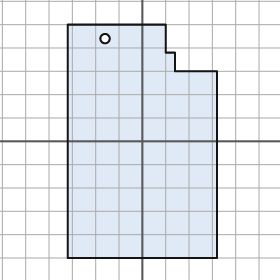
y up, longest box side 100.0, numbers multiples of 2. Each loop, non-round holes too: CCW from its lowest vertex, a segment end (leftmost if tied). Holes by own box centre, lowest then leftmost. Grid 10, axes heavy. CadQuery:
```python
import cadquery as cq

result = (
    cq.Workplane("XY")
    .moveTo(-32.0, -50.0)
    .lineTo(32.0, -50.0)
    .lineTo(32.0, 30.0)
    .lineTo(14.0, 30.0)
    .lineTo(14.0, 38.0)
    .lineTo(10.0, 38.0)
    .lineTo(10.0, 50.0)
    .lineTo(-32.0, 50.0)
    .close()
    .moveTo(-16.0, 44.0)
    .circle(2.0)
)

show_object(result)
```